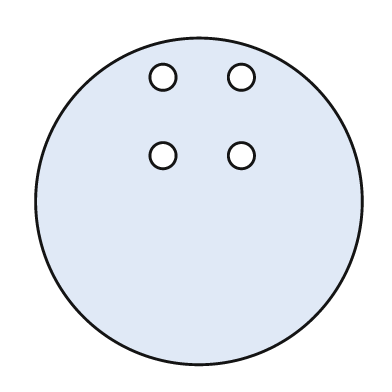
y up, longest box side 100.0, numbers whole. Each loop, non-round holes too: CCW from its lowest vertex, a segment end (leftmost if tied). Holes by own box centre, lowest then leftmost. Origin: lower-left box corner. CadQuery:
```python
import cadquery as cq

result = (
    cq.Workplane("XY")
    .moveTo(50.0, 50.0)
    .circle(50.0)
    .moveTo(39.0, 64.0)
    .circle(4.0)
    .moveTo(63.0, 64.0)
    .circle(4.0)
    .moveTo(39.0, 88.0)
    .circle(4.0)
    .moveTo(63.0, 88.0)
    .circle(4.0)
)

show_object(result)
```